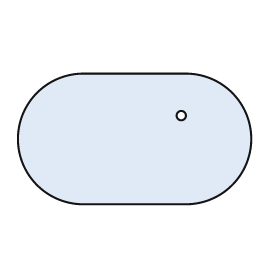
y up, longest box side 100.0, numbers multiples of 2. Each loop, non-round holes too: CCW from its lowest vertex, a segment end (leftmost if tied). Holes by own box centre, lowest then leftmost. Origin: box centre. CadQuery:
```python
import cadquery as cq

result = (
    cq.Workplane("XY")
    .moveTo(-22.0, -28.0)
    .lineTo(22.0, -28.0)
    .threePointArc((50.0, 0.0), (22.0, 28.0))
    .lineTo(-22.0, 28.0)
    .threePointArc((-50.0, 0.0), (-22.0, -28.0))
    .close()
    .moveTo(20.0, 10.0)
    .circle(2.0)
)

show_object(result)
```